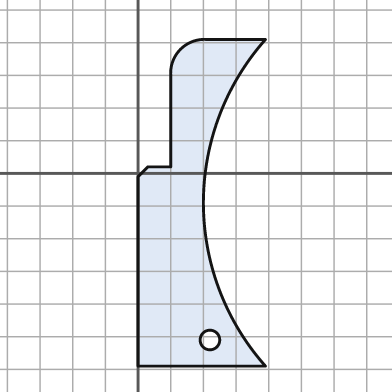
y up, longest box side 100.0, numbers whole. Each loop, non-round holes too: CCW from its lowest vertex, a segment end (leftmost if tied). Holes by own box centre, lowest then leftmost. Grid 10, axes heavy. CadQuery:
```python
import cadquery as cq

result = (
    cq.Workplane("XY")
    .moveTo(0.0, -59.0)
    .lineTo(39.0, -59.0)
    .threePointArc((20.0, -9.0), (39.0, 41.0))
    .lineTo(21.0, 41.0)
    .threePointArc((13.0, 38.0), (10.0, 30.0))
    .lineTo(10.0, 2.0)
    .lineTo(3.0, 2.0)
    .lineTo(0.0, -1.0)
    .close()
    .moveTo(22.0, -51.0)
    .circle(3.0)
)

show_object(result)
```